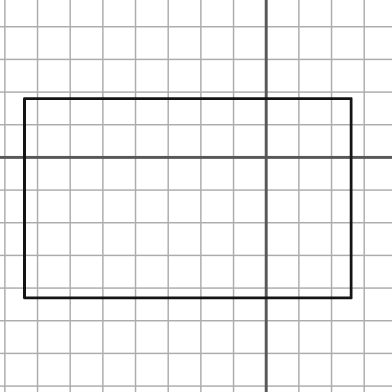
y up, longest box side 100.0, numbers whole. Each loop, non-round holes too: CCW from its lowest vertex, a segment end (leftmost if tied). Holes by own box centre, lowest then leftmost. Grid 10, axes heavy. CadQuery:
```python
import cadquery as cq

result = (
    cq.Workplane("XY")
    .moveTo(-74.0, -43.0)
    .lineTo(26.0, -43.0)
    .lineTo(26.0, 18.0)
    .lineTo(-74.0, 18.0)
    .close()
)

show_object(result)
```